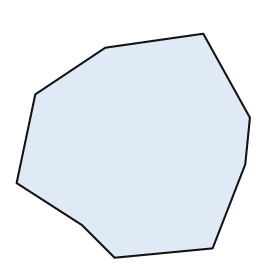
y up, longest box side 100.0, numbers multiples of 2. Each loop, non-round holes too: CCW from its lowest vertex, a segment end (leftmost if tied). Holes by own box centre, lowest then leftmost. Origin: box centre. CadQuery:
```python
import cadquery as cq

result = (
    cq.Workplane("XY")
    .moveTo(-8.0, -48.0)
    .lineTo(34.0, -44.0)
    .lineTo(48.0, -8.0)
    .lineTo(50.0, 12.0)
    .lineTo(30.0, 48.0)
    .lineTo(-12.0, 42.0)
    .lineTo(-42.0, 22.0)
    .lineTo(-50.0, -16.0)
    .lineTo(-22.0, -34.0)
    .close()
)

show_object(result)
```